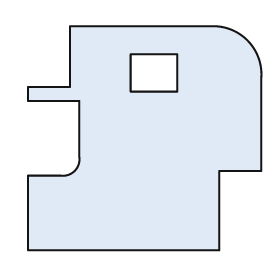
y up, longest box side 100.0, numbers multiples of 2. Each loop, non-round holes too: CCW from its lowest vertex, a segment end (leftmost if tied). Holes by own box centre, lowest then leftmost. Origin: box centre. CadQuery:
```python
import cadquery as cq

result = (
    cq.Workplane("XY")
    .moveTo(-50.0, -48.0)
    .lineTo(32.0, -48.0)
    .lineTo(32.0, -14.0)
    .lineTo(50.0, -14.0)
    .lineTo(50.0, 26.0)
    .threePointArc((44.0, 42.0), (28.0, 48.0))
    .lineTo(-32.0, 48.0)
    .lineTo(-32.0, 22.0)
    .lineTo(-50.0, 22.0)
    .lineTo(-50.0, 16.0)
    .lineTo(-28.0, 16.0)
    .lineTo(-28.0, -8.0)
    .threePointArc((-30.0, -14.0), (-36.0, -16.0))
    .lineTo(-50.0, -16.0)
    .close()
    .moveTo(-6.0, 20.0)
    .lineTo(14.0, 20.0)
    .lineTo(14.0, 36.0)
    .lineTo(-6.0, 36.0)
    .close()
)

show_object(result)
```